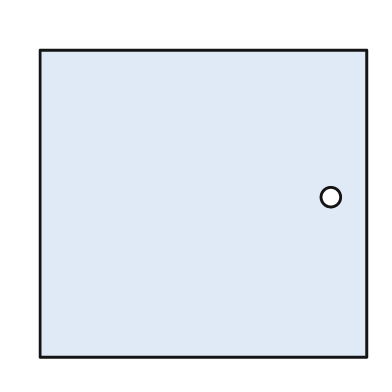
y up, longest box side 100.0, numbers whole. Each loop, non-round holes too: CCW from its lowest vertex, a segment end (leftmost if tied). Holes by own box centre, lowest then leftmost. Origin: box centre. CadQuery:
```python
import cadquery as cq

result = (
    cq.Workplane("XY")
    .moveTo(-50.0, -47.0)
    .lineTo(50.0, -47.0)
    .lineTo(50.0, 47.0)
    .lineTo(-50.0, 47.0)
    .close()
    .moveTo(39.0, 2.0)
    .circle(3.0)
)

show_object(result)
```